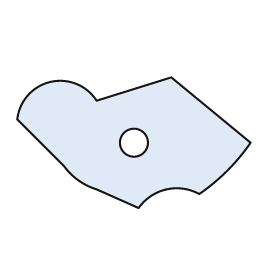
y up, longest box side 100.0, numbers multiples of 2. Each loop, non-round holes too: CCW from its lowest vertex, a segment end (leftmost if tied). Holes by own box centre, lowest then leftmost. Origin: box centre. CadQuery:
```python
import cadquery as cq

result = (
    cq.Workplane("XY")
    .moveTo(2.0, -28.0)
    .threePointArc((14.0, -20.0), (28.0, -22.0))
    .threePointArc((40.0, -12.0), (50.0, 0.0))
    .lineTo(16.0, 28.0)
    .lineTo(-16.0, 18.0)
    .threePointArc((-36.0, 26.0), (-50.0, 10.0))
    .lineTo(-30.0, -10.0)
    .threePointArc((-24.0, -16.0), (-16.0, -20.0))
    .close()
    .moveTo(0.0, 0.0)
    .circle(6.0)
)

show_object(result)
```